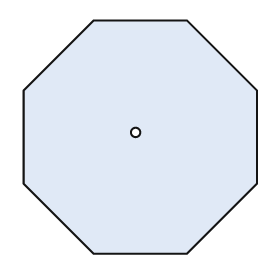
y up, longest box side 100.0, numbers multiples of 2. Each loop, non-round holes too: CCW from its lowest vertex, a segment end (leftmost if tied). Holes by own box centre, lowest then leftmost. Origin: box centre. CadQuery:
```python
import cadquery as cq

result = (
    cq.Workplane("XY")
    .moveTo(-20.0, -50.0)
    .lineTo(20.0, -50.0)
    .lineTo(50.0, -20.0)
    .lineTo(50.0, 20.0)
    .lineTo(20.0, 50.0)
    .lineTo(-20.0, 50.0)
    .lineTo(-50.0, 20.0)
    .lineTo(-50.0, -20.0)
    .close()
    .moveTo(-2.0, 2.0)
    .circle(2.0)
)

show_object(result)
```